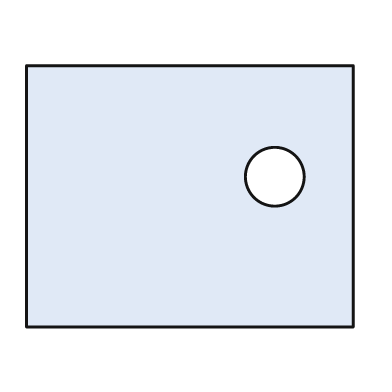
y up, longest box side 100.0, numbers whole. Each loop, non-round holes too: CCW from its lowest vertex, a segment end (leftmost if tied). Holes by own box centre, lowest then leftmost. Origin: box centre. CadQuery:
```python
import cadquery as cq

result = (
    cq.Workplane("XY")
    .moveTo(-50.0, -40.0)
    .lineTo(50.0, -40.0)
    .lineTo(50.0, 40.0)
    .lineTo(-50.0, 40.0)
    .close()
    .moveTo(26.0, 6.0)
    .circle(9.0)
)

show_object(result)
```